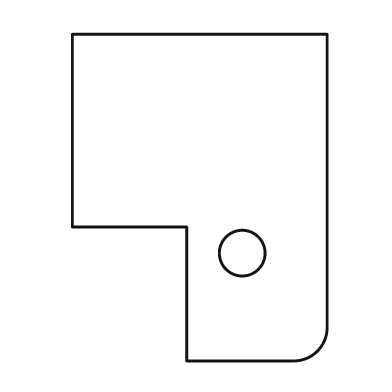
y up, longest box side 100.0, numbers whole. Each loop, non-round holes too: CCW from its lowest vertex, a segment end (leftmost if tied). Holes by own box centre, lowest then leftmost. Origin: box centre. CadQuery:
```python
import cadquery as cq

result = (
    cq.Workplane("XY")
    .moveTo(-4.0, -50.0)
    .lineTo(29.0, -50.0)
    .threePointArc((36.0, -47.0), (39.0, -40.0))
    .lineTo(39.0, 50.0)
    .lineTo(-39.0, 50.0)
    .lineTo(-39.0, -9.0)
    .lineTo(-4.0, -9.0)
    .close()
    .moveTo(13.0, -17.0)
    .circle(7.0)
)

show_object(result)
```